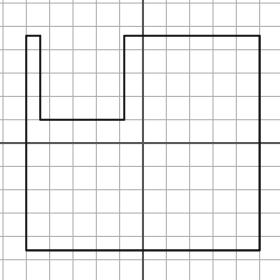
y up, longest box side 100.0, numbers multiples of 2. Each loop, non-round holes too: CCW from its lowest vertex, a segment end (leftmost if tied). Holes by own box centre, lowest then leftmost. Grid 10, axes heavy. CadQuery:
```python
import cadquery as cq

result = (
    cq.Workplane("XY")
    .moveTo(-50.0, -46.0)
    .lineTo(50.0, -46.0)
    .lineTo(50.0, 46.0)
    .lineTo(-8.0, 46.0)
    .lineTo(-8.0, 10.0)
    .lineTo(-44.0, 10.0)
    .lineTo(-44.0, 46.0)
    .lineTo(-50.0, 46.0)
    .close()
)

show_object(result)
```